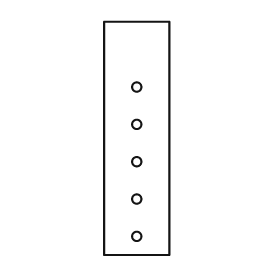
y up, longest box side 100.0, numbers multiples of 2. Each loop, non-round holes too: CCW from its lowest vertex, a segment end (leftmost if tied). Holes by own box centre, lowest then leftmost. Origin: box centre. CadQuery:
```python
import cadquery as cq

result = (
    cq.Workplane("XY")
    .moveTo(-14.0, -50.0)
    .lineTo(14.0, -50.0)
    .lineTo(14.0, 50.0)
    .lineTo(-14.0, 50.0)
    .close()
    .moveTo(0.0, -42.0)
    .circle(2.0)
    .moveTo(0.0, -26.0)
    .circle(2.0)
    .moveTo(0.0, -10.0)
    .circle(2.0)
    .moveTo(0.0, 6.0)
    .circle(2.0)
    .moveTo(0.0, 22.0)
    .circle(2.0)
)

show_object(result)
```